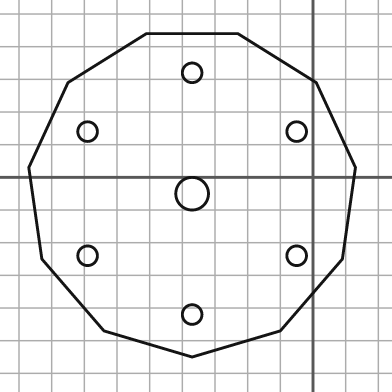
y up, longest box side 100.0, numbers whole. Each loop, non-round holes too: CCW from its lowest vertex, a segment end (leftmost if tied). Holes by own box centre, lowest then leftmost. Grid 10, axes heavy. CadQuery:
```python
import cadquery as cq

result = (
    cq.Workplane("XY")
    .moveTo(-37.0, -55.0)
    .lineTo(-10.0, -47.0)
    .lineTo(9.0, -25.0)
    .lineTo(13.0, 3.0)
    .lineTo(1.0, 29.0)
    .lineTo(-23.0, 44.0)
    .lineTo(-51.0, 44.0)
    .lineTo(-75.0, 29.0)
    .lineTo(-87.0, 3.0)
    .lineTo(-83.0, -25.0)
    .lineTo(-64.0, -47.0)
    .close()
    .moveTo(-37.0, -42.0)
    .circle(3.0)
    .moveTo(-69.0, -24.0)
    .circle(3.0)
    .moveTo(-5.0, -24.0)
    .circle(3.0)
    .moveTo(-37.0, -5.0)
    .circle(5.0)
    .moveTo(-69.0, 14.0)
    .circle(3.0)
    .moveTo(-5.0, 14.0)
    .circle(3.0)
    .moveTo(-37.0, 32.0)
    .circle(3.0)
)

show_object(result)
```